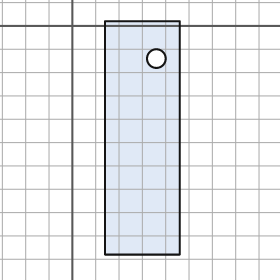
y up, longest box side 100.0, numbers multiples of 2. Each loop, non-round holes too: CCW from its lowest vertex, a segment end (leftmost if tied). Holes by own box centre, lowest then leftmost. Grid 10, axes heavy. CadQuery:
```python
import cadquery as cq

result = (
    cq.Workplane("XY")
    .moveTo(14.0, -98.0)
    .lineTo(46.0, -98.0)
    .lineTo(46.0, 2.0)
    .lineTo(14.0, 2.0)
    .close()
    .moveTo(36.0, -14.0)
    .circle(4.0)
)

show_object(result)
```